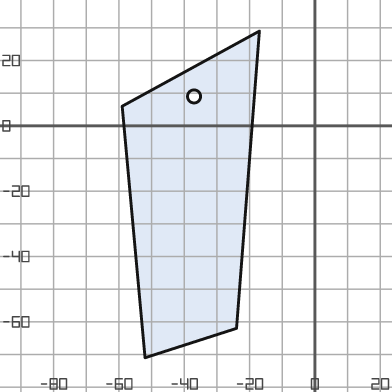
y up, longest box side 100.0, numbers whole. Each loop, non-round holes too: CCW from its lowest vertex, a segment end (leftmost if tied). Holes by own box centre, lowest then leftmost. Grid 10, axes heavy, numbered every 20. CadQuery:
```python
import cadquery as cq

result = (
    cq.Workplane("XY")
    .moveTo(-52.0, -71.0)
    .lineTo(-24.0, -62.0)
    .lineTo(-17.0, 29.0)
    .lineTo(-59.0, 6.0)
    .close()
    .moveTo(-37.0, 9.0)
    .circle(2.0)
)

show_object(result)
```